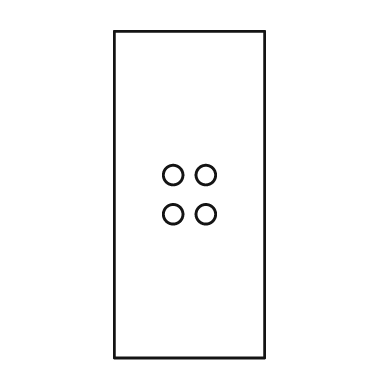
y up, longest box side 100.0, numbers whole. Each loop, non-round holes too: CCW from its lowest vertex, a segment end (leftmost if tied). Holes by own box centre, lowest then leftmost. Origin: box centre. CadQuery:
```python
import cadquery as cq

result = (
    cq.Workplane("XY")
    .moveTo(-23.0, -50.0)
    .lineTo(23.0, -50.0)
    .lineTo(23.0, 50.0)
    .lineTo(-23.0, 50.0)
    .close()
    .moveTo(-5.0, -6.0)
    .circle(3.0)
    .moveTo(5.0, -6.0)
    .circle(3.0)
    .moveTo(-5.0, 6.0)
    .circle(3.0)
    .moveTo(5.0, 6.0)
    .circle(3.0)
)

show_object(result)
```